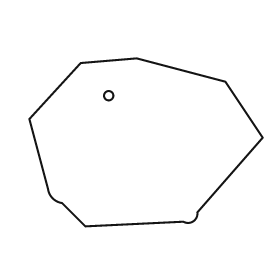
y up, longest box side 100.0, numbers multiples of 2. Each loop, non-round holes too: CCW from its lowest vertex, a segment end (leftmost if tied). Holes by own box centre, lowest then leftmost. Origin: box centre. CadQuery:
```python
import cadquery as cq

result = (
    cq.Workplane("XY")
    .moveTo(-26.0, -36.0)
    .lineTo(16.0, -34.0)
    .threePointArc((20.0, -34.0), (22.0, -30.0))
    .lineTo(50.0, 2.0)
    .lineTo(34.0, 26.0)
    .lineTo(-4.0, 36.0)
    .lineTo(-28.0, 34.0)
    .lineTo(-50.0, 10.0)
    .lineTo(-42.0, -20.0)
    .threePointArc((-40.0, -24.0), (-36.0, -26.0))
    .close()
    .moveTo(-16.0, 20.0)
    .circle(2.0)
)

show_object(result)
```